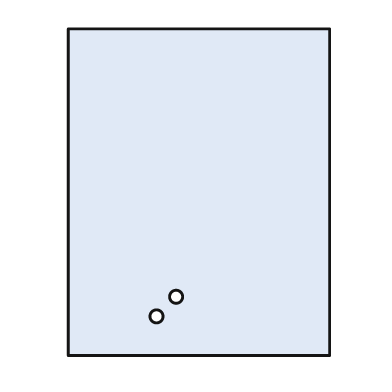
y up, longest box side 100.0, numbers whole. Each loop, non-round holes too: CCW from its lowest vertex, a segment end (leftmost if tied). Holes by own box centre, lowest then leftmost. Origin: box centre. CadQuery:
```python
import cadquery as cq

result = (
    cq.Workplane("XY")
    .moveTo(-40.0, -50.0)
    .lineTo(40.0, -50.0)
    .lineTo(40.0, 50.0)
    .lineTo(-40.0, 50.0)
    .close()
    .moveTo(-13.0, -38.0)
    .circle(2.0)
    .moveTo(-7.0, -32.0)
    .circle(2.0)
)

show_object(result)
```